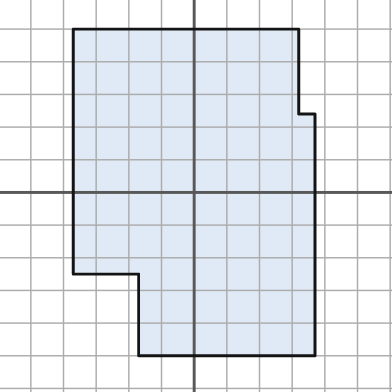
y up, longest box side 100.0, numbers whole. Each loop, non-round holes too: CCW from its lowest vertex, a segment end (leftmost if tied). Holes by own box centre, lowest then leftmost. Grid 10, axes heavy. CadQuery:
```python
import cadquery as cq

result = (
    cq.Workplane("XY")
    .moveTo(-17.0, -50.0)
    .lineTo(37.0, -50.0)
    .lineTo(37.0, 24.0)
    .lineTo(32.0, 24.0)
    .lineTo(32.0, 50.0)
    .lineTo(-37.0, 50.0)
    .lineTo(-37.0, -25.0)
    .lineTo(-17.0, -25.0)
    .close()
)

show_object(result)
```